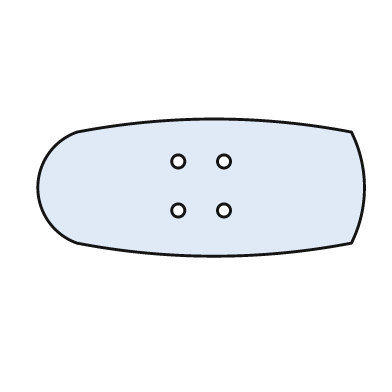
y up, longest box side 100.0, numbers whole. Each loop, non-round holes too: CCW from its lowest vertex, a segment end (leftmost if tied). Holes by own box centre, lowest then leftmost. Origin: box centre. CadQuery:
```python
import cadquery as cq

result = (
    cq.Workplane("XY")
    .moveTo(-38.0, -17.0)
    .threePointArc((4.0, -21.0), (46.0, -17.0))
    .threePointArc((50.0, 0.0), (46.0, 17.0))
    .threePointArc((4.0, 21.0), (-38.0, 17.0))
    .threePointArc((-50.0, 0.0), (-38.0, -17.0))
    .close()
    .moveTo(-7.0, -7.0)
    .circle(2.0)
    .moveTo(7.0, -7.0)
    .circle(2.0)
    .moveTo(-7.0, 8.0)
    .circle(2.0)
    .moveTo(7.0, 8.0)
    .circle(2.0)
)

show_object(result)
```